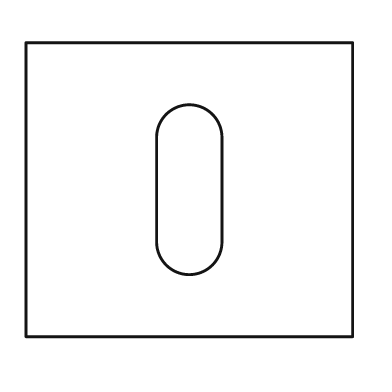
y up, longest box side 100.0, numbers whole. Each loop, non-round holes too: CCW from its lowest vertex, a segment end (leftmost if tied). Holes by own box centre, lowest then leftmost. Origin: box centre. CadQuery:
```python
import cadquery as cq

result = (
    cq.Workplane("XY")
    .moveTo(-50.0, -45.0)
    .lineTo(50.0, -45.0)
    .lineTo(50.0, 45.0)
    .lineTo(-50.0, 45.0)
    .close()
    .moveTo(-10.0, -16.0)
    .threePointArc((0.0, -26.0), (10.0, -16.0))
    .lineTo(10.0, 16.0)
    .threePointArc((0.0, 26.0), (-10.0, 16.0))
    .close()
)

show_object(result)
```